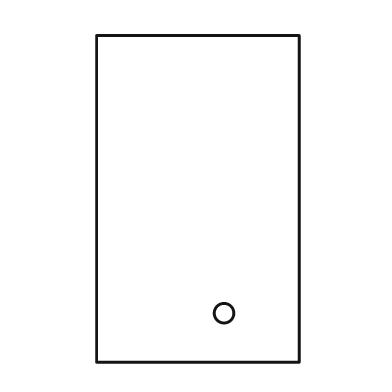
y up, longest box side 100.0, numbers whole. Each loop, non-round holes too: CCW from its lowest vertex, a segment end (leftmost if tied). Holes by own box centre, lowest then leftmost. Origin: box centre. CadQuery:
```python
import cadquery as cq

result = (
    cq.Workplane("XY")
    .moveTo(-31.0, -50.0)
    .lineTo(31.0, -50.0)
    .lineTo(31.0, 50.0)
    .lineTo(-31.0, 50.0)
    .close()
    .moveTo(8.0, -35.0)
    .circle(3.0)
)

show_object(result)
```